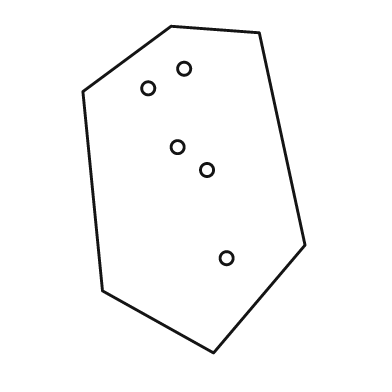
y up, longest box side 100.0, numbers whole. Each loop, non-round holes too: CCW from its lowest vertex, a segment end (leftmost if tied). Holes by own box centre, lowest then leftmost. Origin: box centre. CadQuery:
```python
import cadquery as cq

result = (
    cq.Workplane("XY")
    .moveTo(6.0, -50.0)
    .lineTo(34.0, -17.0)
    .lineTo(20.0, 48.0)
    .lineTo(-7.0, 50.0)
    .lineTo(-34.0, 30.0)
    .lineTo(-28.0, -31.0)
    .close()
    .moveTo(10.0, -21.0)
    .circle(2.0)
    .moveTo(4.0, 6.0)
    .circle(2.0)
    .moveTo(-5.0, 13.0)
    .circle(2.0)
    .moveTo(-14.0, 31.0)
    .circle(2.0)
    .moveTo(-3.0, 37.0)
    .circle(2.0)
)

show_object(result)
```